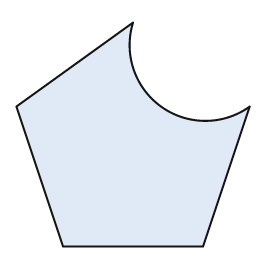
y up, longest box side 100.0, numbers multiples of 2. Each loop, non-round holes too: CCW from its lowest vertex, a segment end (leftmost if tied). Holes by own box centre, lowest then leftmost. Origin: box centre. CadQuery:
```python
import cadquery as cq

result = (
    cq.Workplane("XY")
    .moveTo(-30.0, -48.0)
    .lineTo(30.0, -48.0)
    .lineTo(50.0, 12.0)
    .threePointArc((12.0, 12.0), (0.0, 48.0))
    .lineTo(-50.0, 12.0)
    .close()
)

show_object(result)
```